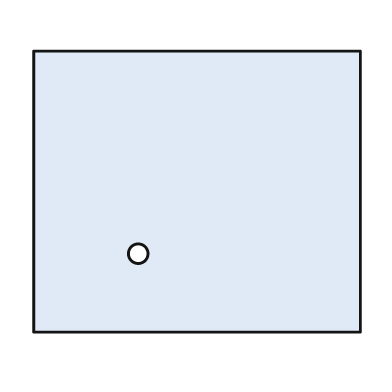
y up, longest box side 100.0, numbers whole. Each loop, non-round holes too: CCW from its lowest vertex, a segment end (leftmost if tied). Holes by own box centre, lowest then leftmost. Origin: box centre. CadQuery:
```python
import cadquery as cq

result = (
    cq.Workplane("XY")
    .moveTo(-50.0, -43.0)
    .lineTo(50.0, -43.0)
    .lineTo(50.0, 43.0)
    .lineTo(-50.0, 43.0)
    .close()
    .moveTo(-18.0, -19.0)
    .circle(3.0)
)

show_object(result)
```